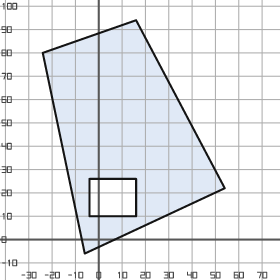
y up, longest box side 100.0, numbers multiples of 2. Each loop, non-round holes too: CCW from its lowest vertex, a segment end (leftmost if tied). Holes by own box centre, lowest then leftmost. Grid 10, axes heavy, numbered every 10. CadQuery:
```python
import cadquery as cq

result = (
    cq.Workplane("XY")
    .moveTo(-6.0, -6.0)
    .lineTo(54.0, 22.0)
    .lineTo(16.0, 94.0)
    .lineTo(-24.0, 80.0)
    .close()
    .moveTo(-4.0, 10.0)
    .lineTo(16.0, 10.0)
    .lineTo(16.0, 26.0)
    .lineTo(-4.0, 26.0)
    .close()
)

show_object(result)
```